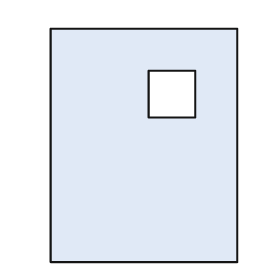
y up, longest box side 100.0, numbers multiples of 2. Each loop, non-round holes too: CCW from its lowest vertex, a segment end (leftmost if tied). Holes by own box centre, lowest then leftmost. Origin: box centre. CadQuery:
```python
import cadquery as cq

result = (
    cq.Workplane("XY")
    .moveTo(-40.0, -50.0)
    .lineTo(40.0, -50.0)
    .lineTo(40.0, 50.0)
    .lineTo(-40.0, 50.0)
    .close()
    .moveTo(2.0, 12.0)
    .lineTo(22.0, 12.0)
    .lineTo(22.0, 32.0)
    .lineTo(2.0, 32.0)
    .close()
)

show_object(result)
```